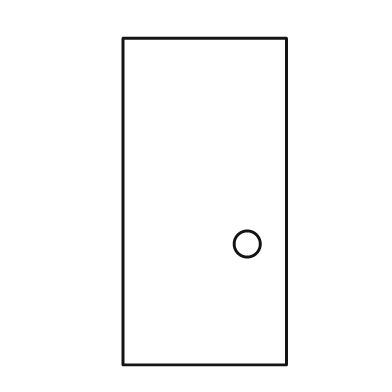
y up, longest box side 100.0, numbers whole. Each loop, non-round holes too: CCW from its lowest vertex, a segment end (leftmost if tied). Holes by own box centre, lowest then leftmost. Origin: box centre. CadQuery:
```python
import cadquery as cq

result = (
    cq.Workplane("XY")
    .moveTo(-25.0, -50.0)
    .lineTo(25.0, -50.0)
    .lineTo(25.0, 50.0)
    .lineTo(-25.0, 50.0)
    .close()
    .moveTo(13.0, -13.0)
    .circle(4.0)
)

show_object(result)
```